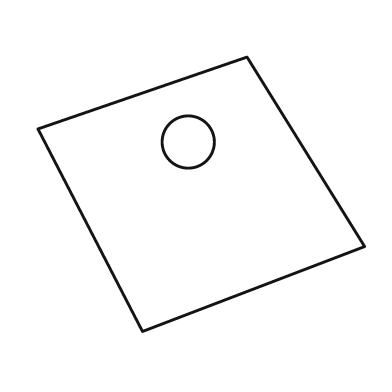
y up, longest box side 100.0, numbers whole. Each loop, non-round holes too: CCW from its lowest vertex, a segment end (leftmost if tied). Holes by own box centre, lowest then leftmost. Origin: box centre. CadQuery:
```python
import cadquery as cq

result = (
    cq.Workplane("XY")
    .moveTo(-18.0, -42.0)
    .lineTo(50.0, -16.0)
    .lineTo(14.0, 42.0)
    .lineTo(-50.0, 20.0)
    .close()
    .moveTo(-4.0, 16.0)
    .circle(8.0)
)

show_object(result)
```